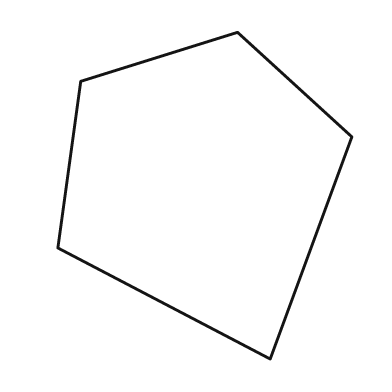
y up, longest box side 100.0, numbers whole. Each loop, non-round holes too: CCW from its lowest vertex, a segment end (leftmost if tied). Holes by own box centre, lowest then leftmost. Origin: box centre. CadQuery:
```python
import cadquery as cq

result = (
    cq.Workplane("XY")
    .moveTo(20.0, -50.0)
    .lineTo(45.0, 18.0)
    .lineTo(10.0, 50.0)
    .lineTo(-38.0, 35.0)
    .lineTo(-45.0, -16.0)
    .close()
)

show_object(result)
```